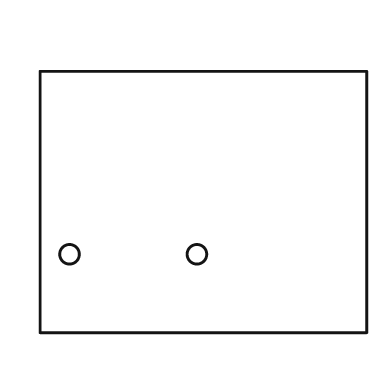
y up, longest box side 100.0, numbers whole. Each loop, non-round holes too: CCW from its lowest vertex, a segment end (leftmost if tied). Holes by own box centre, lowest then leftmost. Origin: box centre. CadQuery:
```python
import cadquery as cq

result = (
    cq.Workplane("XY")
    .moveTo(-50.0, -40.0)
    .lineTo(50.0, -40.0)
    .lineTo(50.0, 40.0)
    .lineTo(-50.0, 40.0)
    .close()
    .moveTo(-41.0, -16.0)
    .circle(3.0)
    .moveTo(-2.0, -16.0)
    .circle(3.0)
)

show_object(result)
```